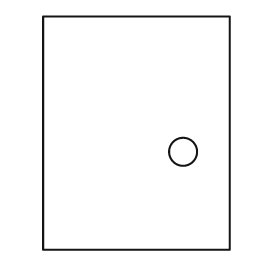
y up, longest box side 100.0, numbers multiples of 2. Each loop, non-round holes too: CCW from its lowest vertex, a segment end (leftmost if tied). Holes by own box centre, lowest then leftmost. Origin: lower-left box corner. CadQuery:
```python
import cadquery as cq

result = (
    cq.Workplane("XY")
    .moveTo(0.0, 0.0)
    .lineTo(80.0, 0.0)
    .lineTo(80.0, 100.0)
    .lineTo(0.0, 100.0)
    .close()
    .moveTo(60.0, 42.0)
    .circle(6.0)
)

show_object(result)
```